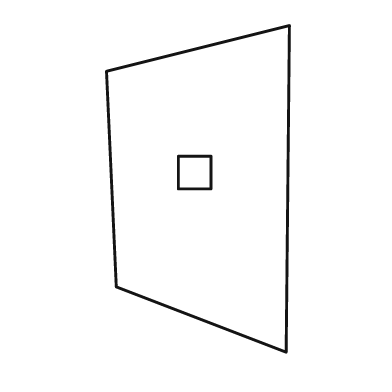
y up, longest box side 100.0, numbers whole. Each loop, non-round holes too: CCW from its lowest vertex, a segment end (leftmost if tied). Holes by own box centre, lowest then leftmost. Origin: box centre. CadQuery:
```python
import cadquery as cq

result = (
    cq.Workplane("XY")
    .moveTo(27.0, -50.0)
    .lineTo(28.0, 50.0)
    .lineTo(-28.0, 36.0)
    .lineTo(-25.0, -30.0)
    .close()
    .moveTo(-6.0, 0.0)
    .lineTo(4.0, 0.0)
    .lineTo(4.0, 10.0)
    .lineTo(-6.0, 10.0)
    .close()
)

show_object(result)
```